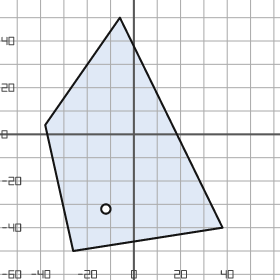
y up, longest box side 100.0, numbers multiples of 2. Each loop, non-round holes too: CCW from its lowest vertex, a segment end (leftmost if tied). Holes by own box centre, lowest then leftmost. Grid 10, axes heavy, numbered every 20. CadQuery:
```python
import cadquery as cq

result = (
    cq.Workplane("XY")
    .moveTo(-26.0, -50.0)
    .lineTo(38.0, -40.0)
    .lineTo(-6.0, 50.0)
    .lineTo(-38.0, 4.0)
    .close()
    .moveTo(-12.0, -32.0)
    .circle(2.0)
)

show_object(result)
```